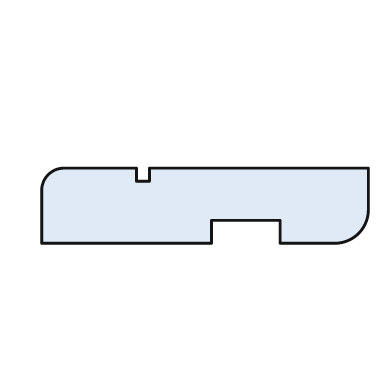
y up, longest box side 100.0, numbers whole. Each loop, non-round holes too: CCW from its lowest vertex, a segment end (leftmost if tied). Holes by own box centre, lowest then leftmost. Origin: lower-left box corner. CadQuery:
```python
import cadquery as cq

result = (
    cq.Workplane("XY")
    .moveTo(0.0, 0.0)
    .lineTo(52.0, 0.0)
    .lineTo(52.0, 7.0)
    .lineTo(73.0, 7.0)
    .lineTo(73.0, 0.0)
    .lineTo(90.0, 0.0)
    .threePointArc((97.0, 3.0), (100.0, 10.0))
    .lineTo(100.0, 23.0)
    .lineTo(33.0, 23.0)
    .lineTo(33.0, 19.0)
    .lineTo(29.0, 19.0)
    .lineTo(29.0, 23.0)
    .lineTo(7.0, 23.0)
    .threePointArc((2.0, 21.0), (0.0, 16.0))
    .close()
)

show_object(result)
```